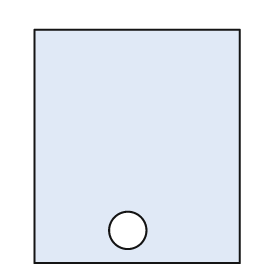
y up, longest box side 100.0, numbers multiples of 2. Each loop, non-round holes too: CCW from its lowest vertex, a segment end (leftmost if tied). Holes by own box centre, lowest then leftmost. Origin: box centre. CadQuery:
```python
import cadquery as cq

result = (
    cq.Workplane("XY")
    .moveTo(-44.0, -50.0)
    .lineTo(44.0, -50.0)
    .lineTo(44.0, 50.0)
    .lineTo(-44.0, 50.0)
    .close()
    .moveTo(-4.0, -36.0)
    .circle(8.0)
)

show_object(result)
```